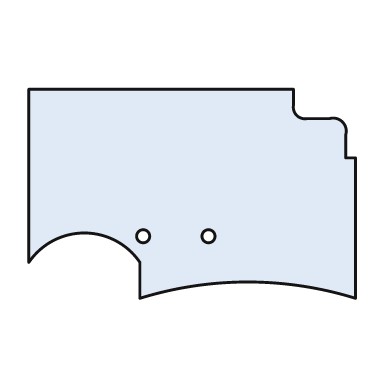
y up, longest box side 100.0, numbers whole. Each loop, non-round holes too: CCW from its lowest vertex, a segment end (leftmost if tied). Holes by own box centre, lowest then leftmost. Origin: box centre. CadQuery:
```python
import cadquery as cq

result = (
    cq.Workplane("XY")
    .moveTo(-16.0, -32.0)
    .threePointArc((17.0, -27.0), (50.0, -32.0))
    .lineTo(50.0, 11.0)
    .lineTo(47.0, 11.0)
    .lineTo(47.0, 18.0)
    .threePointArc((46.0, 22.0), (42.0, 23.0))
    .lineTo(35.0, 23.0)
    .threePointArc((32.0, 24.0), (31.0, 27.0))
    .lineTo(31.0, 32.0)
    .lineTo(-50.0, 32.0)
    .lineTo(-50.0, -21.0)
    .threePointArc((-33.0, -12.0), (-16.0, -21.0))
    .close()
    .moveTo(-15.0, -13.0)
    .circle(2.0)
    .moveTo(5.0, -13.0)
    .circle(2.0)
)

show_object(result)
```